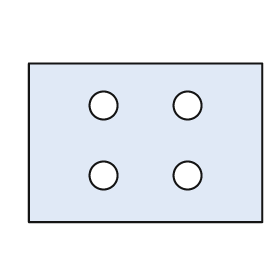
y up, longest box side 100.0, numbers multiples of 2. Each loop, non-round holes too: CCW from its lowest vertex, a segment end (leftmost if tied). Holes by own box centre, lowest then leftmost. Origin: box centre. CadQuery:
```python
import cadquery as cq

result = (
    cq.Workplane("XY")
    .moveTo(-50.0, -34.0)
    .lineTo(50.0, -34.0)
    .lineTo(50.0, 34.0)
    .lineTo(-50.0, 34.0)
    .close()
    .moveTo(-18.0, -14.0)
    .circle(6.0)
    .moveTo(18.0, -14.0)
    .circle(6.0)
    .moveTo(-18.0, 16.0)
    .circle(6.0)
    .moveTo(18.0, 16.0)
    .circle(6.0)
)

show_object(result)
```